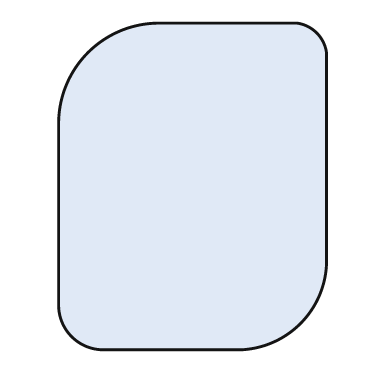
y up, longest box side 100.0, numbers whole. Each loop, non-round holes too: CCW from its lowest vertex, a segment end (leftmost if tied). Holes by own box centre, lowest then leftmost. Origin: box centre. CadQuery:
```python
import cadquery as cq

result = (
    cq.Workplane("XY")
    .moveTo(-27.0, -50.0)
    .lineTo(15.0, -50.0)
    .threePointArc((33.0, -42.0), (41.0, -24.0))
    .lineTo(41.0, 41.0)
    .threePointArc((38.0, 47.0), (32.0, 50.0))
    .lineTo(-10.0, 50.0)
    .threePointArc((-32.0, 41.0), (-41.0, 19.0))
    .lineTo(-41.0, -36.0)
    .threePointArc((-37.0, -46.0), (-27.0, -50.0))
    .close()
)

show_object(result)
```